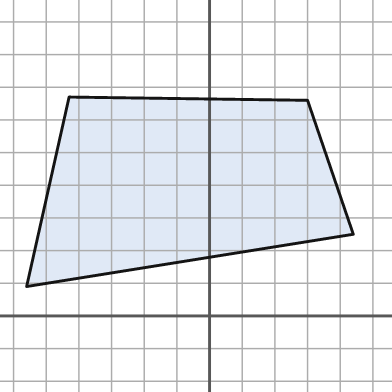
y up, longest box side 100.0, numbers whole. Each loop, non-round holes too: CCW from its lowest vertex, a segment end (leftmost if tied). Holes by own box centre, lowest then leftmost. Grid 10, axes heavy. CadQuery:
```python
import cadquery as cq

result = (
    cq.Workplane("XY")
    .moveTo(-56.0, 9.0)
    .lineTo(44.0, 25.0)
    .lineTo(30.0, 66.0)
    .lineTo(-43.0, 67.0)
    .close()
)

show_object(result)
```